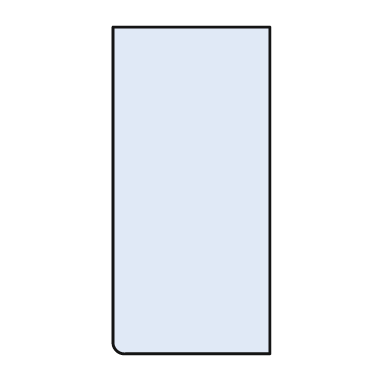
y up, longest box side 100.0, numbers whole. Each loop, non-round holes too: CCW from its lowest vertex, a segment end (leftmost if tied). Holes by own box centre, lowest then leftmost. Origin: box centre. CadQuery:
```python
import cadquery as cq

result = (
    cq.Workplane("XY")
    .moveTo(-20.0, -50.0)
    .lineTo(24.0, -50.0)
    .lineTo(24.0, 50.0)
    .lineTo(-24.0, 50.0)
    .lineTo(-24.0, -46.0)
    .threePointArc((-23.0, -49.0), (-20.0, -50.0))
    .close()
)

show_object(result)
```